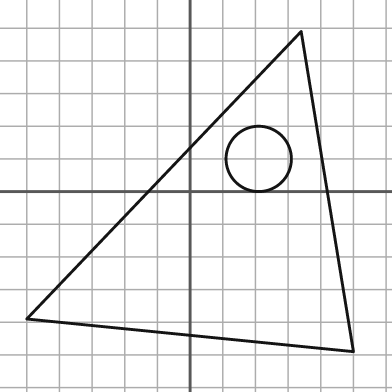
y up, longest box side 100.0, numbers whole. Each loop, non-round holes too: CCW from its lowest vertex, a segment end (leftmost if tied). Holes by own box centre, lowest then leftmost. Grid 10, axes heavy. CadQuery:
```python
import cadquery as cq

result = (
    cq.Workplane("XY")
    .moveTo(50.0, -49.0)
    .lineTo(34.0, 49.0)
    .lineTo(-50.0, -39.0)
    .close()
    .moveTo(21.0, 10.0)
    .circle(10.0)
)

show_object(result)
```